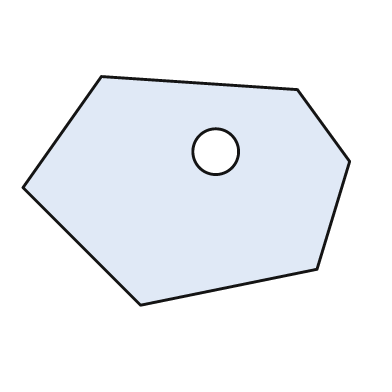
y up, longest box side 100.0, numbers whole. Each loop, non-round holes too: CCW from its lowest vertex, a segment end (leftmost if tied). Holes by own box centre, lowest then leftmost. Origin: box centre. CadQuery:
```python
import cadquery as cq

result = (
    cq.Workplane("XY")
    .moveTo(-14.0, -35.0)
    .lineTo(40.0, -24.0)
    .lineTo(50.0, 9.0)
    .lineTo(34.0, 31.0)
    .lineTo(-26.0, 35.0)
    .lineTo(-50.0, 1.0)
    .close()
    .moveTo(9.0, 12.0)
    .circle(7.0)
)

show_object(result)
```